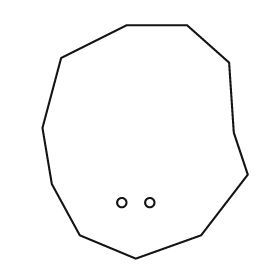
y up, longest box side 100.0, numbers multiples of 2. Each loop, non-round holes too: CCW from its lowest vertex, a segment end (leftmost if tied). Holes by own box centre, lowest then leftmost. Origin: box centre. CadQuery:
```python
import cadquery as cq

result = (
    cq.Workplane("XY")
    .moveTo(-4.0, -50.0)
    .lineTo(24.0, -40.0)
    .lineTo(44.0, -14.0)
    .lineTo(38.0, 4.0)
    .lineTo(36.0, 34.0)
    .lineTo(18.0, 50.0)
    .lineTo(-8.0, 50.0)
    .lineTo(-36.0, 36.0)
    .lineTo(-44.0, 6.0)
    .lineTo(-40.0, -18.0)
    .lineTo(-28.0, -40.0)
    .close()
    .moveTo(-10.0, -26.0)
    .circle(2.0)
    .moveTo(2.0, -26.0)
    .circle(2.0)
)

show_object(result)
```